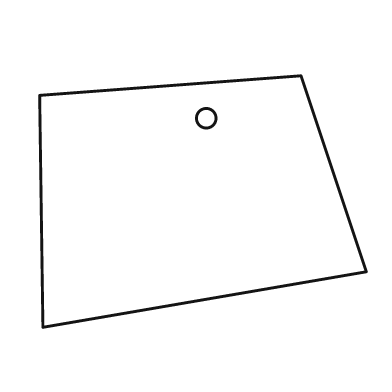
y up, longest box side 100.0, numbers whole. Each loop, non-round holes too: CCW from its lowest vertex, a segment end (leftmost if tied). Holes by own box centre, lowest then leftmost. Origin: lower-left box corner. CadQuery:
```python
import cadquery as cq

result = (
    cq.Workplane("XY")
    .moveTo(1.0, 0.0)
    .lineTo(100.0, 17.0)
    .lineTo(80.0, 77.0)
    .lineTo(0.0, 71.0)
    .close()
    .moveTo(51.0, 64.0)
    .circle(3.0)
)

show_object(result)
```